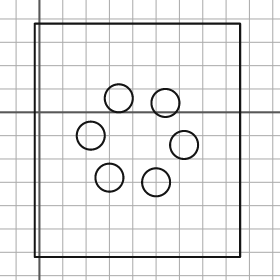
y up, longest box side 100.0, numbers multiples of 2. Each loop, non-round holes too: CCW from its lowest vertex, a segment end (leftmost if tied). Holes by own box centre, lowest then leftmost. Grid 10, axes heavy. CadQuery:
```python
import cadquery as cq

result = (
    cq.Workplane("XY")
    .moveTo(-2.0, -62.0)
    .lineTo(86.0, -62.0)
    .lineTo(86.0, 38.0)
    .lineTo(-2.0, 38.0)
    .close()
    .moveTo(50.0, -30.0)
    .circle(6.0)
    .moveTo(30.0, -28.0)
    .circle(6.0)
    .moveTo(62.0, -14.0)
    .circle(6.0)
    .moveTo(22.0, -10.0)
    .circle(6.0)
    .moveTo(54.0, 4.0)
    .circle(6.0)
    .moveTo(34.0, 6.0)
    .circle(6.0)
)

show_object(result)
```